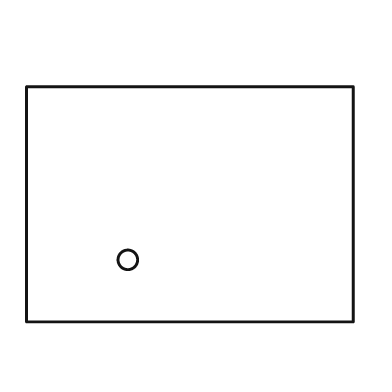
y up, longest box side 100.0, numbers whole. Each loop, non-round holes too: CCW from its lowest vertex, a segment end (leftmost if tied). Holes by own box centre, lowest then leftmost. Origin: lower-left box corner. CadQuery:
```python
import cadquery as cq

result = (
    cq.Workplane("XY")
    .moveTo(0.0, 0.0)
    .lineTo(100.0, 0.0)
    .lineTo(100.0, 72.0)
    .lineTo(0.0, 72.0)
    .close()
    .moveTo(31.0, 19.0)
    .circle(3.0)
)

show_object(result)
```